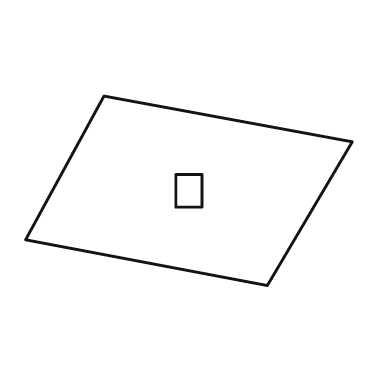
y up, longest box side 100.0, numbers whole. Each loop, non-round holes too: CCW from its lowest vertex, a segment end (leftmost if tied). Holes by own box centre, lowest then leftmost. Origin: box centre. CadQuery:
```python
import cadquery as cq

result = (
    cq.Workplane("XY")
    .moveTo(24.0, -29.0)
    .lineTo(50.0, 15.0)
    .lineTo(-26.0, 29.0)
    .lineTo(-50.0, -15.0)
    .close()
    .moveTo(-4.0, -5.0)
    .lineTo(4.0, -5.0)
    .lineTo(4.0, 5.0)
    .lineTo(-4.0, 5.0)
    .close()
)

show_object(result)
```